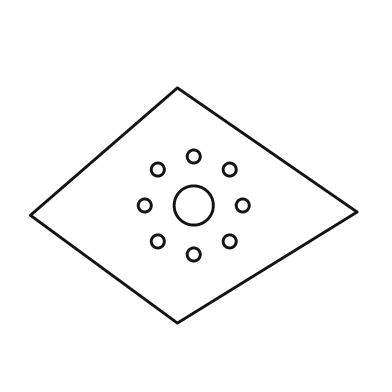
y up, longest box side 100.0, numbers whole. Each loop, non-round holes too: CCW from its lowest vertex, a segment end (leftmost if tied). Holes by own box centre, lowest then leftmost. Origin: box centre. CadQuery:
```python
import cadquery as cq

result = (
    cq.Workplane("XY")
    .moveTo(-5.0, -36.0)
    .lineTo(50.0, -2.0)
    .lineTo(-5.0, 36.0)
    .lineTo(-50.0, -3.0)
    .close()
    .moveTo(0.0, -15.0)
    .circle(2.0)
    .moveTo(-11.0, -11.0)
    .circle(2.0)
    .moveTo(11.0, -11.0)
    .circle(2.0)
    .moveTo(-15.0, 0.0)
    .circle(2.0)
    .moveTo(0.0, 0.0)
    .circle(6.0)
    .moveTo(15.0, 0.0)
    .circle(2.0)
    .moveTo(-11.0, 11.0)
    .circle(2.0)
    .moveTo(11.0, 11.0)
    .circle(2.0)
    .moveTo(0.0, 15.0)
    .circle(2.0)
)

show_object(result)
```